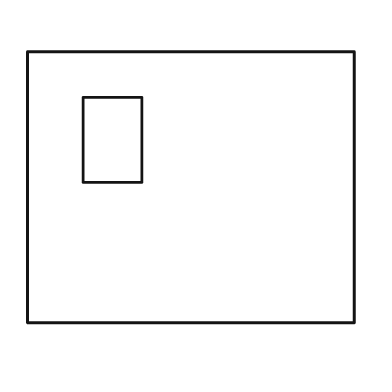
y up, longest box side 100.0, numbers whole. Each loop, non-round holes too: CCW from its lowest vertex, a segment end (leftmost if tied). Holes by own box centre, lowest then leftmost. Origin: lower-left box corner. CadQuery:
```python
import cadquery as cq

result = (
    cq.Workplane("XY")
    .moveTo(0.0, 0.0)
    .lineTo(100.0, 0.0)
    .lineTo(100.0, 83.0)
    .lineTo(0.0, 83.0)
    .close()
    .moveTo(17.0, 43.0)
    .lineTo(35.0, 43.0)
    .lineTo(35.0, 69.0)
    .lineTo(17.0, 69.0)
    .close()
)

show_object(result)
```